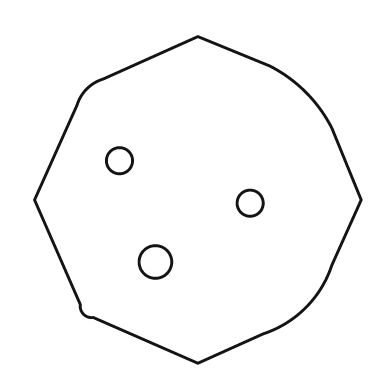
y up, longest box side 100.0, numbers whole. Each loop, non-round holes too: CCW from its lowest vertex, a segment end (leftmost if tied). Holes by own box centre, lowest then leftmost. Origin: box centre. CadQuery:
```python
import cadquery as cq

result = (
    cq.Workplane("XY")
    .moveTo(0.0, -50.0)
    .lineTo(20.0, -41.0)
    .threePointArc((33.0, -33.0), (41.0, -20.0))
    .lineTo(50.0, 0.0)
    .lineTo(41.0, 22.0)
    .threePointArc((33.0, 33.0), (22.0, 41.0))
    .lineTo(0.0, 50.0)
    .lineTo(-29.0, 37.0)
    .threePointArc((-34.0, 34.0), (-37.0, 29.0))
    .lineTo(-50.0, 0.0)
    .lineTo(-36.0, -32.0)
    .threePointArc((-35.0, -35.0), (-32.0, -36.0))
    .close()
    .moveTo(-13.0, -19.0)
    .circle(5.0)
    .moveTo(16.0, -1.0)
    .circle(4.0)
    .moveTo(-24.0, 12.0)
    .circle(4.0)
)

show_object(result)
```